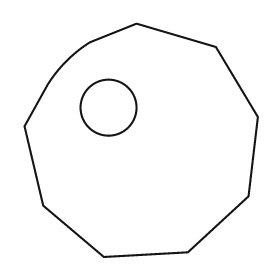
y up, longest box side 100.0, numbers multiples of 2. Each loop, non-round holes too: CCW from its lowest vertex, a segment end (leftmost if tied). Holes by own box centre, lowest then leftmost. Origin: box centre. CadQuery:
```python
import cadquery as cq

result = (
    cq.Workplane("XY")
    .moveTo(-16.0, -50.0)
    .lineTo(20.0, -48.0)
    .lineTo(46.0, -24.0)
    .lineTo(50.0, 10.0)
    .lineTo(32.0, 40.0)
    .lineTo(-2.0, 50.0)
    .lineTo(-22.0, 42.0)
    .threePointArc((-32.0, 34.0), (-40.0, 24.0))
    .lineTo(-50.0, 6.0)
    .lineTo(-42.0, -28.0)
    .close()
    .moveTo(-14.0, 14.0)
    .circle(12.0)
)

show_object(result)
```